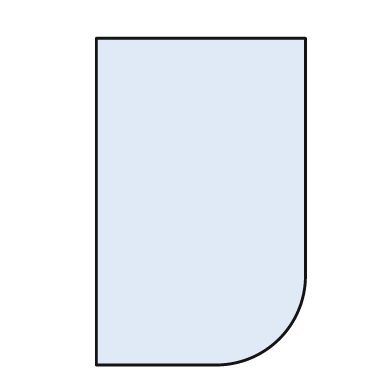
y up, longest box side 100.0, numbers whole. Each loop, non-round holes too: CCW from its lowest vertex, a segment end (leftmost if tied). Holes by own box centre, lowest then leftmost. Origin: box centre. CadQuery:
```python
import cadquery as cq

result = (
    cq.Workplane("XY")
    .moveTo(-32.0, -50.0)
    .lineTo(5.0, -50.0)
    .threePointArc((24.0, -42.0), (32.0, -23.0))
    .lineTo(32.0, 50.0)
    .lineTo(-32.0, 50.0)
    .close()
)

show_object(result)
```